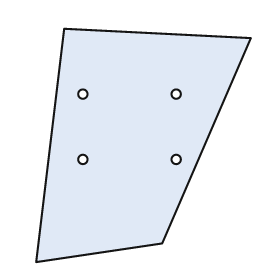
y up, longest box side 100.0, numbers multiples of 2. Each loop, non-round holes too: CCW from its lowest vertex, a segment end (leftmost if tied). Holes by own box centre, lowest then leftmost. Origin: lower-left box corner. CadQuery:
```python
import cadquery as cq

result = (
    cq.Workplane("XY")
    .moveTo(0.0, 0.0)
    .lineTo(54.0, 8.0)
    .lineTo(92.0, 96.0)
    .lineTo(12.0, 100.0)
    .close()
    .moveTo(20.0, 44.0)
    .circle(2.0)
    .moveTo(60.0, 44.0)
    .circle(2.0)
    .moveTo(20.0, 72.0)
    .circle(2.0)
    .moveTo(60.0, 72.0)
    .circle(2.0)
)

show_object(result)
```